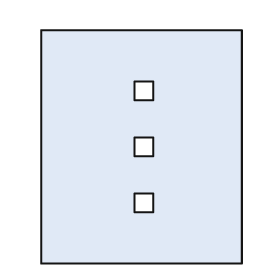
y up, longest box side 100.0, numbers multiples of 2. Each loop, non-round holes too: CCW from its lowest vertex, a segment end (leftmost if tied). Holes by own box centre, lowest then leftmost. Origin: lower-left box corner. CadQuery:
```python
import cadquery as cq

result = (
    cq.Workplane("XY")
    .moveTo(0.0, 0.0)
    .lineTo(86.0, 0.0)
    .lineTo(86.0, 100.0)
    .lineTo(0.0, 100.0)
    .close()
    .moveTo(40.0, 22.0)
    .lineTo(48.0, 22.0)
    .lineTo(48.0, 30.0)
    .lineTo(40.0, 30.0)
    .close()
    .moveTo(40.0, 46.0)
    .lineTo(48.0, 46.0)
    .lineTo(48.0, 54.0)
    .lineTo(40.0, 54.0)
    .close()
    .moveTo(40.0, 70.0)
    .lineTo(48.0, 70.0)
    .lineTo(48.0, 78.0)
    .lineTo(40.0, 78.0)
    .close()
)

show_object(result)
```